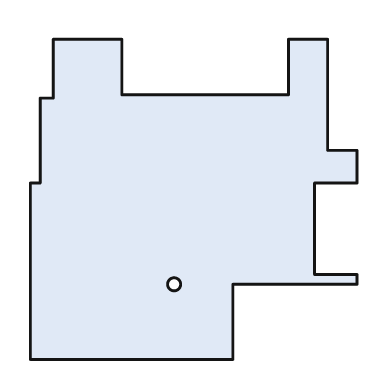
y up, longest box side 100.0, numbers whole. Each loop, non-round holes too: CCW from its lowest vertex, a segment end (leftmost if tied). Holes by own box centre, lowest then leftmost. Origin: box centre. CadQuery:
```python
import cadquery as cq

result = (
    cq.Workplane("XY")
    .moveTo(-50.0, -49.0)
    .lineTo(12.0, -49.0)
    .lineTo(12.0, -26.0)
    .lineTo(50.0, -26.0)
    .lineTo(50.0, -23.0)
    .lineTo(37.0, -23.0)
    .lineTo(37.0, 5.0)
    .lineTo(50.0, 5.0)
    .lineTo(50.0, 15.0)
    .lineTo(41.0, 15.0)
    .lineTo(41.0, 49.0)
    .lineTo(29.0, 49.0)
    .lineTo(29.0, 32.0)
    .lineTo(-22.0, 32.0)
    .lineTo(-22.0, 49.0)
    .lineTo(-43.0, 49.0)
    .lineTo(-43.0, 31.0)
    .lineTo(-47.0, 31.0)
    .lineTo(-47.0, 5.0)
    .lineTo(-50.0, 5.0)
    .close()
    .moveTo(-6.0, -26.0)
    .circle(2.0)
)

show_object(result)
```